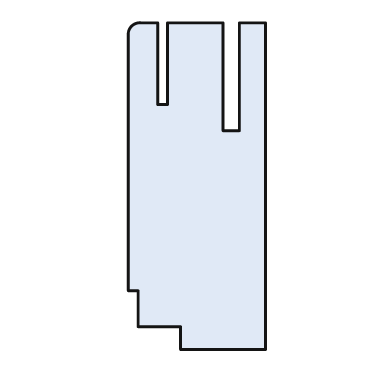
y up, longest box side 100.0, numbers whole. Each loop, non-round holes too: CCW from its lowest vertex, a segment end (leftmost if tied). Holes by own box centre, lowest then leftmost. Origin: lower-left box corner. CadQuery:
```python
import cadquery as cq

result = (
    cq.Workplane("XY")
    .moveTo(16.0, 0.0)
    .lineTo(42.0, 0.0)
    .lineTo(42.0, 100.0)
    .lineTo(34.0, 100.0)
    .lineTo(34.0, 67.0)
    .lineTo(29.0, 67.0)
    .lineTo(29.0, 100.0)
    .lineTo(12.0, 100.0)
    .lineTo(12.0, 75.0)
    .lineTo(9.0, 75.0)
    .lineTo(9.0, 100.0)
    .lineTo(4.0, 100.0)
    .threePointArc((1.0, 99.0), (0.0, 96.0))
    .lineTo(0.0, 18.0)
    .lineTo(3.0, 18.0)
    .lineTo(3.0, 7.0)
    .lineTo(16.0, 7.0)
    .close()
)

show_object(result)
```